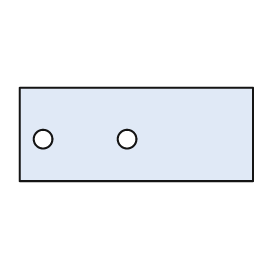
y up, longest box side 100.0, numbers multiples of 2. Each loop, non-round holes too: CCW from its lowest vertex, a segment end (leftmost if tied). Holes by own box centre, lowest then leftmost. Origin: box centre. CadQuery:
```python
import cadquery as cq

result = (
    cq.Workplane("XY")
    .moveTo(-50.0, -20.0)
    .lineTo(50.0, -20.0)
    .lineTo(50.0, 20.0)
    .lineTo(-50.0, 20.0)
    .close()
    .moveTo(-40.0, -2.0)
    .circle(4.0)
    .moveTo(-4.0, -2.0)
    .circle(4.0)
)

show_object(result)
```